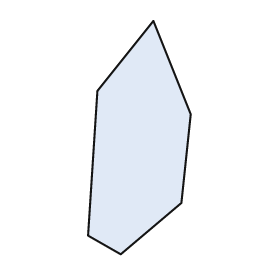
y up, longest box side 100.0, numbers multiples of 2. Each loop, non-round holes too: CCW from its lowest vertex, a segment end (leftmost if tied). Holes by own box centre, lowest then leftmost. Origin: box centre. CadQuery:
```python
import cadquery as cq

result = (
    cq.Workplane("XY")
    .moveTo(-8.0, -50.0)
    .lineTo(18.0, -28.0)
    .lineTo(22.0, 10.0)
    .lineTo(6.0, 50.0)
    .lineTo(-18.0, 20.0)
    .lineTo(-22.0, -42.0)
    .close()
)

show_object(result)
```